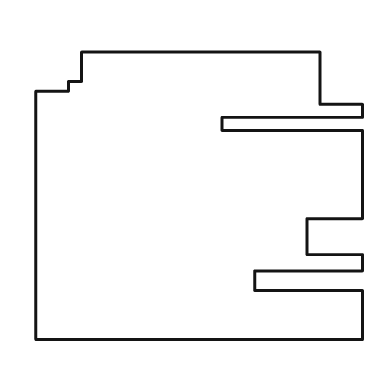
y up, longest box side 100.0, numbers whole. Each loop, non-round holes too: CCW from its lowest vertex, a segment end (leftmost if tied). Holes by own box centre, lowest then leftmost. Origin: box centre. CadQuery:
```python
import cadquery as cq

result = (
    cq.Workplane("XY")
    .moveTo(-50.0, -44.0)
    .lineTo(50.0, -44.0)
    .lineTo(50.0, -29.0)
    .lineTo(17.0, -29.0)
    .lineTo(17.0, -23.0)
    .lineTo(50.0, -23.0)
    .lineTo(50.0, -18.0)
    .lineTo(33.0, -18.0)
    .lineTo(33.0, -7.0)
    .lineTo(50.0, -7.0)
    .lineTo(50.0, 20.0)
    .lineTo(7.0, 20.0)
    .lineTo(7.0, 24.0)
    .lineTo(50.0, 24.0)
    .lineTo(50.0, 28.0)
    .lineTo(37.0, 28.0)
    .lineTo(37.0, 44.0)
    .lineTo(-36.0, 44.0)
    .lineTo(-36.0, 35.0)
    .lineTo(-40.0, 35.0)
    .lineTo(-40.0, 32.0)
    .lineTo(-50.0, 32.0)
    .close()
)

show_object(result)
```